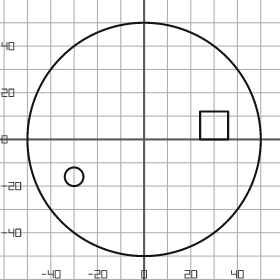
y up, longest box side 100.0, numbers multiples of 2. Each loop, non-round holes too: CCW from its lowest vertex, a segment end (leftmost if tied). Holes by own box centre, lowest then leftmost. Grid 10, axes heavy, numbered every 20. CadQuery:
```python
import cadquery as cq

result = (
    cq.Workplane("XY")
    .moveTo(0.0, 0.0)
    .circle(50.0)
    .moveTo(-30.0, -16.0)
    .circle(4.0)
    .moveTo(24.0, 0.0)
    .lineTo(36.0, 0.0)
    .lineTo(36.0, 12.0)
    .lineTo(24.0, 12.0)
    .close()
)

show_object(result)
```